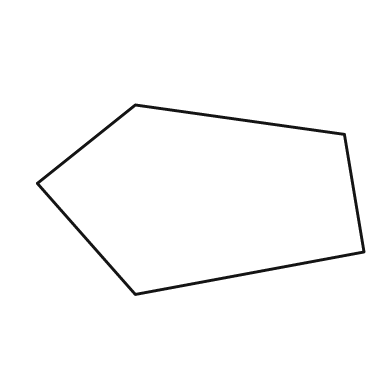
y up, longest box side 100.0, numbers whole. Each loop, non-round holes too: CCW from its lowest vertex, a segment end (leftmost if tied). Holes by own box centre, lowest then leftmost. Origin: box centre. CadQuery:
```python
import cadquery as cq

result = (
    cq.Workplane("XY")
    .moveTo(-20.0, -29.0)
    .lineTo(50.0, -16.0)
    .lineTo(44.0, 20.0)
    .lineTo(-20.0, 29.0)
    .lineTo(-50.0, 5.0)
    .close()
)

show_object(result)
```